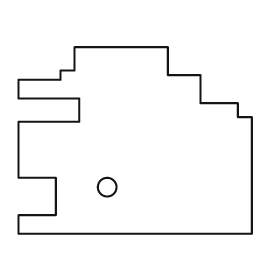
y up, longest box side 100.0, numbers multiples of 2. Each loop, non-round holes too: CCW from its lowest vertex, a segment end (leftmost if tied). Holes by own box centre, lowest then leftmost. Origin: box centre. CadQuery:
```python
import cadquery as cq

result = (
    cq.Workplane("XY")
    .moveTo(-50.0, -40.0)
    .lineTo(50.0, -40.0)
    .lineTo(50.0, 10.0)
    .lineTo(44.0, 10.0)
    .lineTo(44.0, 16.0)
    .lineTo(28.0, 16.0)
    .lineTo(28.0, 28.0)
    .lineTo(14.0, 28.0)
    .lineTo(14.0, 40.0)
    .lineTo(-26.0, 40.0)
    .lineTo(-26.0, 30.0)
    .lineTo(-32.0, 30.0)
    .lineTo(-32.0, 26.0)
    .lineTo(-50.0, 26.0)
    .lineTo(-50.0, 18.0)
    .lineTo(-24.0, 18.0)
    .lineTo(-24.0, 8.0)
    .lineTo(-50.0, 8.0)
    .lineTo(-50.0, -16.0)
    .lineTo(-34.0, -16.0)
    .lineTo(-34.0, -32.0)
    .lineTo(-50.0, -32.0)
    .close()
    .moveTo(-12.0, -20.0)
    .circle(4.0)
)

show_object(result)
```